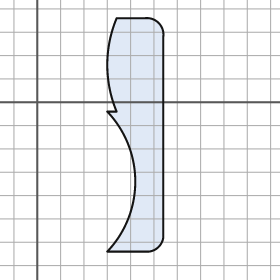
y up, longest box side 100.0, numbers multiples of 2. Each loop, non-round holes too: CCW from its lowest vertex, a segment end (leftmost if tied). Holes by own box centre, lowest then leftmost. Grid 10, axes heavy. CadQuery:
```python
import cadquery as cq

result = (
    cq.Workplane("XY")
    .moveTo(30.0, -64.0)
    .lineTo(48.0, -64.0)
    .threePointArc((52.0, -62.0), (54.0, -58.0))
    .lineTo(54.0, 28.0)
    .threePointArc((52.0, 34.0), (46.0, 36.0))
    .lineTo(34.0, 36.0)
    .threePointArc((30.0, 16.0), (34.0, -4.0))
    .lineTo(30.0, -4.0)
    .threePointArc((42.0, -34.0), (30.0, -64.0))
    .close()
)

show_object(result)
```